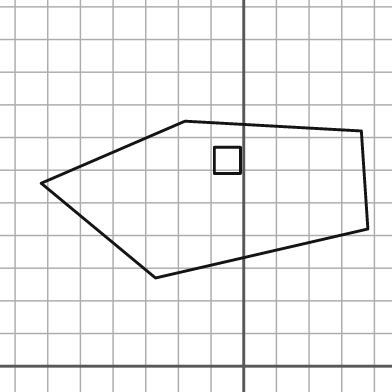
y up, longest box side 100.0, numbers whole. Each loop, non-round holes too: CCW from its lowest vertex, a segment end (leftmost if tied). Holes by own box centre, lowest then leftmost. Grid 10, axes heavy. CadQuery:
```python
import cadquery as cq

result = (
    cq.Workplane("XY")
    .moveTo(-27.0, 27.0)
    .lineTo(38.0, 42.0)
    .lineTo(36.0, 72.0)
    .lineTo(-18.0, 75.0)
    .lineTo(-62.0, 56.0)
    .close()
    .moveTo(-9.0, 59.0)
    .lineTo(-1.0, 59.0)
    .lineTo(-1.0, 67.0)
    .lineTo(-9.0, 67.0)
    .close()
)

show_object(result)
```